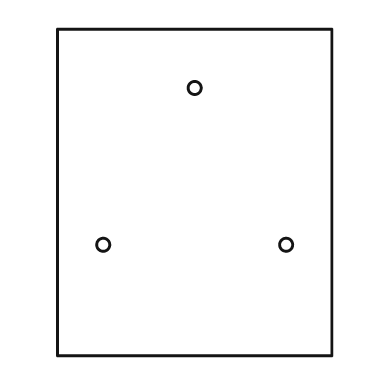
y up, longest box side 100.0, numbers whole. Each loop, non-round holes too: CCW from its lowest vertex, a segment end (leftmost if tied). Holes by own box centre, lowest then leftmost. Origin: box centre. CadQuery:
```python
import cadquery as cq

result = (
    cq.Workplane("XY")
    .moveTo(-42.0, -50.0)
    .lineTo(42.0, -50.0)
    .lineTo(42.0, 50.0)
    .lineTo(-42.0, 50.0)
    .close()
    .moveTo(-28.0, -16.0)
    .circle(2.0)
    .moveTo(28.0, -16.0)
    .circle(2.0)
    .moveTo(0.0, 32.0)
    .circle(2.0)
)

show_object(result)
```